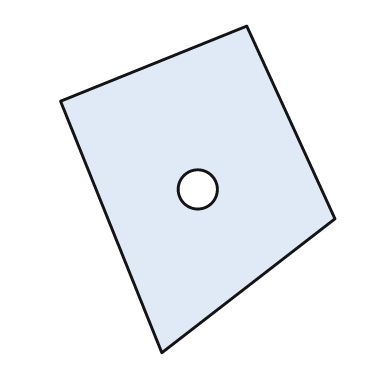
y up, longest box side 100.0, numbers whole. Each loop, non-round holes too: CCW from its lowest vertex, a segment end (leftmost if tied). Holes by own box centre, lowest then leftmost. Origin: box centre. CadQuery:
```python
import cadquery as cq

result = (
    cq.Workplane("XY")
    .moveTo(-11.0, -50.0)
    .lineTo(42.0, -9.0)
    .lineTo(15.0, 50.0)
    .lineTo(-42.0, 27.0)
    .close()
    .moveTo(0.0, 0.0)
    .circle(6.0)
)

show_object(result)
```